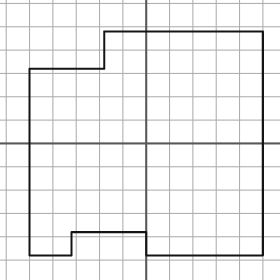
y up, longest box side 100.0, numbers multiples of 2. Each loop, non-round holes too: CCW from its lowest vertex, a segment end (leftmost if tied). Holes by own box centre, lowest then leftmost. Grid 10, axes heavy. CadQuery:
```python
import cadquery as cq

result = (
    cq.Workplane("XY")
    .moveTo(-50.0, -48.0)
    .lineTo(-32.0, -48.0)
    .lineTo(-32.0, -38.0)
    .lineTo(0.0, -38.0)
    .lineTo(0.0, -48.0)
    .lineTo(50.0, -48.0)
    .lineTo(50.0, 48.0)
    .lineTo(-18.0, 48.0)
    .lineTo(-18.0, 32.0)
    .lineTo(-50.0, 32.0)
    .close()
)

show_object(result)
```